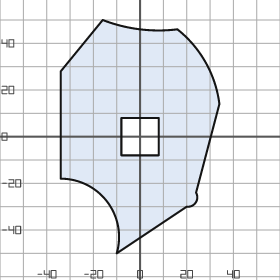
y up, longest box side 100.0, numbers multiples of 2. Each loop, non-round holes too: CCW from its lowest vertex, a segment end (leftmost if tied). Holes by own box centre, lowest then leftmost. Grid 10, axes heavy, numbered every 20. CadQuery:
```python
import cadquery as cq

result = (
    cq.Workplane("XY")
    .moveTo(-10.0, -50.0)
    .lineTo(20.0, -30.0)
    .threePointArc((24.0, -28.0), (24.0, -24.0))
    .lineTo(34.0, 14.0)
    .threePointArc((28.0, 32.0), (16.0, 46.0))
    .threePointArc((0.0, 46.0), (-16.0, 50.0))
    .lineTo(-34.0, 28.0)
    .lineTo(-34.0, -18.0)
    .threePointArc((-14.0, -28.0), (-10.0, -50.0))
    .close()
    .moveTo(-8.0, -8.0)
    .lineTo(8.0, -8.0)
    .lineTo(8.0, 8.0)
    .lineTo(-8.0, 8.0)
    .close()
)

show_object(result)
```